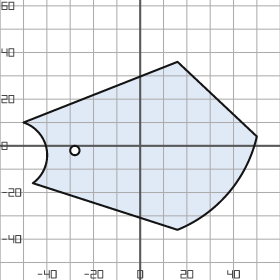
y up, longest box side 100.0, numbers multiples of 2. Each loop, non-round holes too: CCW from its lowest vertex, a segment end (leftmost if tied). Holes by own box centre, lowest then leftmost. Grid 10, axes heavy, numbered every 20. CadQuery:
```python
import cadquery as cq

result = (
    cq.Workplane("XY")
    .moveTo(16.0, -36.0)
    .threePointArc((38.0, -20.0), (50.0, 4.0))
    .lineTo(16.0, 36.0)
    .lineTo(-50.0, 10.0)
    .threePointArc((-40.0, -2.0), (-46.0, -16.0))
    .close()
    .moveTo(-28.0, -2.0)
    .circle(2.0)
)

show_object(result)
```